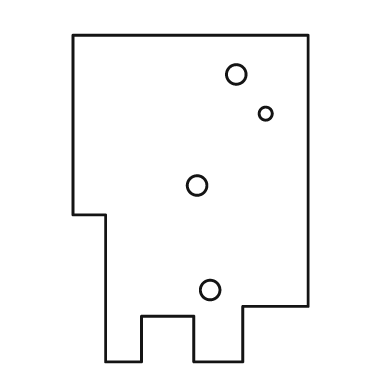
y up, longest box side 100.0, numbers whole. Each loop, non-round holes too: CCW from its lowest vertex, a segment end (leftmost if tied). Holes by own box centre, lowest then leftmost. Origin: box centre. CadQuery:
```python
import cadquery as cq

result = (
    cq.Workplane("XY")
    .moveTo(-26.0, -50.0)
    .lineTo(-15.0, -50.0)
    .lineTo(-15.0, -36.0)
    .lineTo(1.0, -36.0)
    .lineTo(1.0, -50.0)
    .lineTo(16.0, -50.0)
    .lineTo(16.0, -33.0)
    .lineTo(36.0, -33.0)
    .lineTo(36.0, 50.0)
    .lineTo(-36.0, 50.0)
    .lineTo(-36.0, -5.0)
    .lineTo(-26.0, -5.0)
    .close()
    .moveTo(6.0, -28.0)
    .circle(3.0)
    .moveTo(2.0, 4.0)
    .circle(3.0)
    .moveTo(23.0, 26.0)
    .circle(2.0)
    .moveTo(14.0, 38.0)
    .circle(3.0)
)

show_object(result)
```